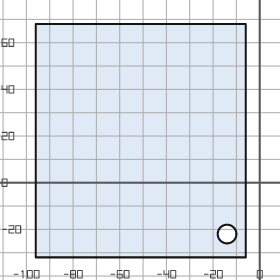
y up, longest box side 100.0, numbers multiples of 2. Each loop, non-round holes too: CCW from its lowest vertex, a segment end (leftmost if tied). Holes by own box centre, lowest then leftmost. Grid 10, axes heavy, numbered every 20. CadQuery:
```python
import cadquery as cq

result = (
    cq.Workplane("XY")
    .moveTo(-96.0, -32.0)
    .lineTo(-6.0, -32.0)
    .lineTo(-6.0, 68.0)
    .lineTo(-96.0, 68.0)
    .close()
    .moveTo(-14.0, -22.0)
    .circle(4.0)
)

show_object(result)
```